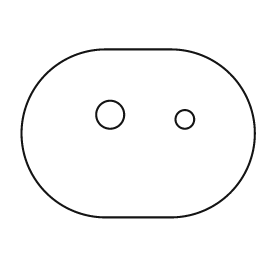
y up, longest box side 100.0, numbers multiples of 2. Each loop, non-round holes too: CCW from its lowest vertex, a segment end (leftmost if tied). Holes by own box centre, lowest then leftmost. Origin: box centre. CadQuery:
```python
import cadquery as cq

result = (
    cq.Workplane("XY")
    .moveTo(-14.0, -36.0)
    .lineTo(14.0, -36.0)
    .threePointArc((50.0, 0.0), (14.0, 36.0))
    .lineTo(-14.0, 36.0)
    .threePointArc((-50.0, 0.0), (-14.0, -36.0))
    .close()
    .moveTo(20.0, 6.0)
    .circle(4.0)
    .moveTo(-12.0, 8.0)
    .circle(6.0)
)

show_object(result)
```